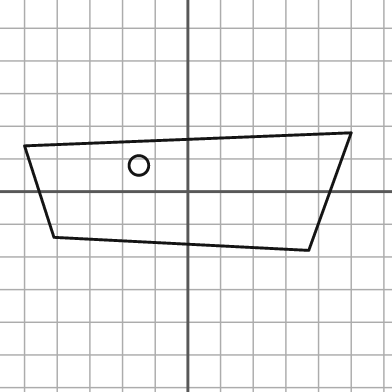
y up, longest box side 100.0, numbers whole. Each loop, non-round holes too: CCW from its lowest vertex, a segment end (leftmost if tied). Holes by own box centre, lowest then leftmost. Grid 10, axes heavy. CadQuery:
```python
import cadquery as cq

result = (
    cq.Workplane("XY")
    .moveTo(37.0, -18.0)
    .lineTo(50.0, 18.0)
    .lineTo(-50.0, 14.0)
    .lineTo(-41.0, -14.0)
    .close()
    .moveTo(-15.0, 8.0)
    .circle(3.0)
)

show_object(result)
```